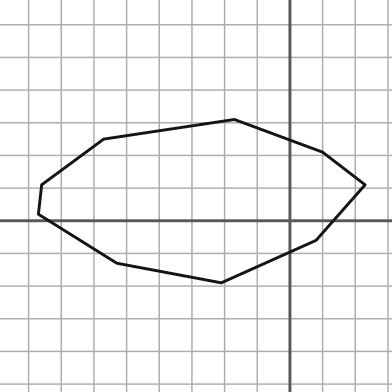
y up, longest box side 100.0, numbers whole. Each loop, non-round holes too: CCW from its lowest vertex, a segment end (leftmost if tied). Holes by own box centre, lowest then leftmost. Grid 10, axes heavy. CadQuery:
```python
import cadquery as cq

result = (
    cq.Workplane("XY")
    .moveTo(-21.0, -19.0)
    .lineTo(8.0, -6.0)
    .lineTo(23.0, 11.0)
    .lineTo(10.0, 21.0)
    .lineTo(-17.0, 31.0)
    .lineTo(-57.0, 25.0)
    .lineTo(-76.0, 11.0)
    .lineTo(-77.0, 2.0)
    .lineTo(-53.0, -13.0)
    .close()
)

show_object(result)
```